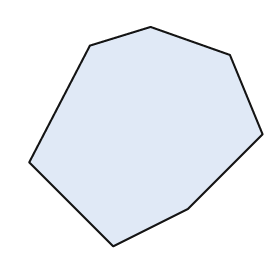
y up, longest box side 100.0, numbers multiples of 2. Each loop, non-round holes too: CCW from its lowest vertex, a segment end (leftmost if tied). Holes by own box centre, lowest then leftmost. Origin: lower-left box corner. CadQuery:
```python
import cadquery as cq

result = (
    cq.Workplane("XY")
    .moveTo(36.0, 0.0)
    .lineTo(68.0, 16.0)
    .lineTo(100.0, 48.0)
    .lineTo(86.0, 82.0)
    .lineTo(52.0, 94.0)
    .lineTo(26.0, 86.0)
    .lineTo(0.0, 36.0)
    .close()
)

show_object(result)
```